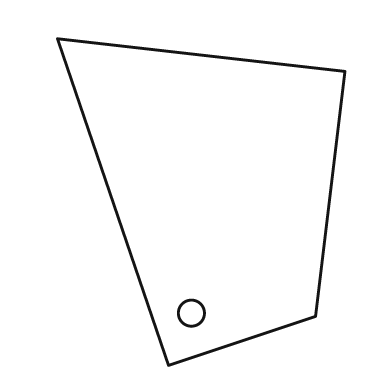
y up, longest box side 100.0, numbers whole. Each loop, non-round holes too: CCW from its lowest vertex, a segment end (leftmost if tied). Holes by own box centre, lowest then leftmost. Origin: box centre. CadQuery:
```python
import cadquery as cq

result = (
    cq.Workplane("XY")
    .moveTo(-10.0, -50.0)
    .lineTo(35.0, -35.0)
    .lineTo(44.0, 40.0)
    .lineTo(-44.0, 50.0)
    .close()
    .moveTo(-3.0, -34.0)
    .circle(4.0)
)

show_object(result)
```